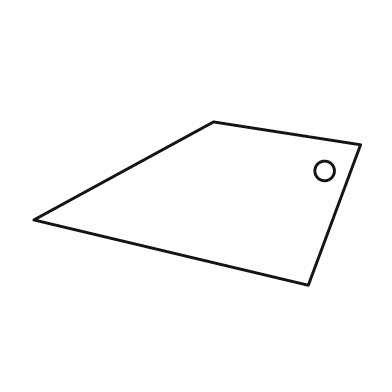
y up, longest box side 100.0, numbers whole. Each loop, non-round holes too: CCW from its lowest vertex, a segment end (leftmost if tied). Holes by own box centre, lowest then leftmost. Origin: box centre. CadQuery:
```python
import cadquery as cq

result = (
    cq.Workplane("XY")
    .moveTo(34.0, -25.0)
    .lineTo(50.0, 18.0)
    .lineTo(5.0, 25.0)
    .lineTo(-50.0, -5.0)
    .close()
    .moveTo(39.0, 10.0)
    .circle(3.0)
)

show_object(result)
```